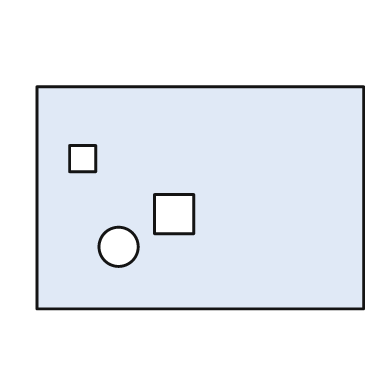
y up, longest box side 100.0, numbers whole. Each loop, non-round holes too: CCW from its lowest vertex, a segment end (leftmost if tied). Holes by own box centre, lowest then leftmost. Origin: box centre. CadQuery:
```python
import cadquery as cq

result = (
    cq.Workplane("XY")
    .moveTo(-50.0, -34.0)
    .lineTo(50.0, -34.0)
    .lineTo(50.0, 34.0)
    .lineTo(-50.0, 34.0)
    .close()
    .moveTo(-25.0, -15.0)
    .circle(6.0)
    .moveTo(-14.0, -11.0)
    .lineTo(-2.0, -11.0)
    .lineTo(-2.0, 1.0)
    .lineTo(-14.0, 1.0)
    .close()
    .moveTo(-40.0, 8.0)
    .lineTo(-32.0, 8.0)
    .lineTo(-32.0, 16.0)
    .lineTo(-40.0, 16.0)
    .close()
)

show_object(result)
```